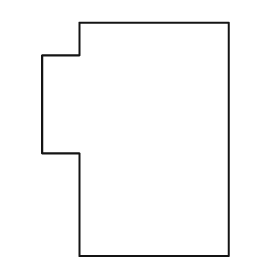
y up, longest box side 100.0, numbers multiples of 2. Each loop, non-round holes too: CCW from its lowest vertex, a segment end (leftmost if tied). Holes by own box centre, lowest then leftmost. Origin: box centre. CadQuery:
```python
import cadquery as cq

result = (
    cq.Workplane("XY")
    .moveTo(-24.0, -50.0)
    .lineTo(40.0, -50.0)
    .lineTo(40.0, 50.0)
    .lineTo(-24.0, 50.0)
    .lineTo(-24.0, 36.0)
    .lineTo(-40.0, 36.0)
    .lineTo(-40.0, -6.0)
    .lineTo(-24.0, -6.0)
    .close()
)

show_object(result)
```